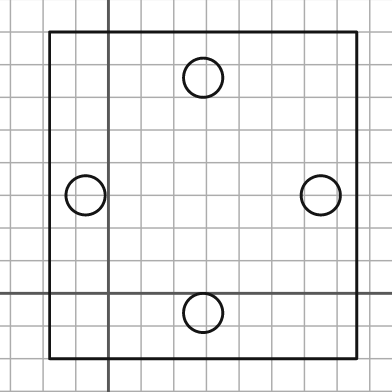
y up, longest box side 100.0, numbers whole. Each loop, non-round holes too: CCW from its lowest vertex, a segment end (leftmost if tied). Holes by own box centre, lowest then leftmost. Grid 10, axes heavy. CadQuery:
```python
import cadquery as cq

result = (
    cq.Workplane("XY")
    .moveTo(-18.0, -20.0)
    .lineTo(76.0, -20.0)
    .lineTo(76.0, 80.0)
    .lineTo(-18.0, 80.0)
    .close()
    .moveTo(29.0, -6.0)
    .circle(6.0)
    .moveTo(-7.0, 30.0)
    .circle(6.0)
    .moveTo(65.0, 30.0)
    .circle(6.0)
    .moveTo(29.0, 66.0)
    .circle(6.0)
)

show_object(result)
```